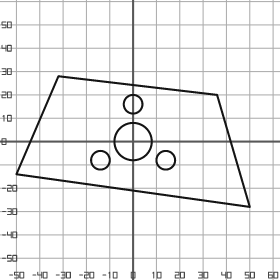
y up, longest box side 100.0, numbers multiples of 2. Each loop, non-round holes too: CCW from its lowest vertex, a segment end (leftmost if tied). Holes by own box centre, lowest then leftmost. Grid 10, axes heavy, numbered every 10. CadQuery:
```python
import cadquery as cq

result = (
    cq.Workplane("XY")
    .moveTo(50.0, -28.0)
    .lineTo(36.0, 20.0)
    .lineTo(-32.0, 28.0)
    .lineTo(-50.0, -14.0)
    .close()
    .moveTo(-14.0, -8.0)
    .circle(4.0)
    .moveTo(14.0, -8.0)
    .circle(4.0)
    .moveTo(0.0, 0.0)
    .circle(8.0)
    .moveTo(0.0, 16.0)
    .circle(4.0)
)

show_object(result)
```